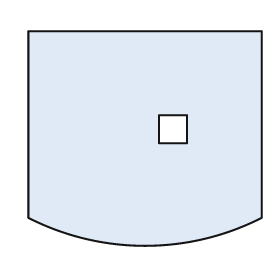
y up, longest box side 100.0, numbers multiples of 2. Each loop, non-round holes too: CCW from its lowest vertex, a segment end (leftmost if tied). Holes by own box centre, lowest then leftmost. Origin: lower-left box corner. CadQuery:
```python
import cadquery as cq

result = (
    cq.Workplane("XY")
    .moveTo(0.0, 12.0)
    .threePointArc((50.0, 0.0), (100.0, 12.0))
    .lineTo(100.0, 92.0)
    .lineTo(0.0, 92.0)
    .close()
    .moveTo(56.0, 44.0)
    .lineTo(68.0, 44.0)
    .lineTo(68.0, 56.0)
    .lineTo(56.0, 56.0)
    .close()
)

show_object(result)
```